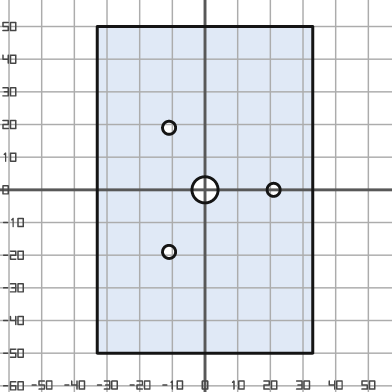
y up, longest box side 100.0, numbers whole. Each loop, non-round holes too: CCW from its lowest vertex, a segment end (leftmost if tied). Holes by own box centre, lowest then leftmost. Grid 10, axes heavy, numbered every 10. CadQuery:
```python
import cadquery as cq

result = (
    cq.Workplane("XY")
    .moveTo(-33.0, -50.0)
    .lineTo(33.0, -50.0)
    .lineTo(33.0, 50.0)
    .lineTo(-33.0, 50.0)
    .close()
    .moveTo(-11.0, -19.0)
    .circle(2.0)
    .moveTo(0.0, 0.0)
    .circle(4.0)
    .moveTo(21.0, 0.0)
    .circle(2.0)
    .moveTo(-11.0, 19.0)
    .circle(2.0)
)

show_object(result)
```